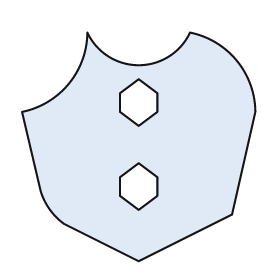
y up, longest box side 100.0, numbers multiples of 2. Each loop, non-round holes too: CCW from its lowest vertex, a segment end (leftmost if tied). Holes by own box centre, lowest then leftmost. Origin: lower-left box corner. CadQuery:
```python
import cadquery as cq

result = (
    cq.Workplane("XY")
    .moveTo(50.0, 0.0)
    .lineTo(90.0, 20.0)
    .lineTo(100.0, 64.0)
    .threePointArc((92.0, 86.0), (72.0, 98.0))
    .threePointArc((50.0, 84.0), (28.0, 98.0))
    .threePointArc((20.0, 76.0), (0.0, 64.0))
    .lineTo(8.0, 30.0)
    .threePointArc((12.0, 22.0), (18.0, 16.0))
    .close()
    .moveTo(50.0, 22.0)
    .lineTo(58.0, 28.0)
    .lineTo(58.0, 36.0)
    .lineTo(50.0, 42.0)
    .lineTo(42.0, 36.0)
    .lineTo(42.0, 28.0)
    .close()
    .moveTo(50.0, 58.0)
    .lineTo(58.0, 64.0)
    .lineTo(58.0, 72.0)
    .lineTo(50.0, 78.0)
    .lineTo(42.0, 72.0)
    .lineTo(42.0, 64.0)
    .close()
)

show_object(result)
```